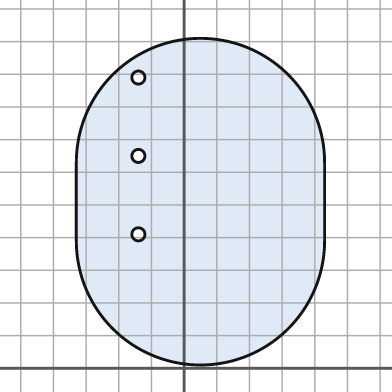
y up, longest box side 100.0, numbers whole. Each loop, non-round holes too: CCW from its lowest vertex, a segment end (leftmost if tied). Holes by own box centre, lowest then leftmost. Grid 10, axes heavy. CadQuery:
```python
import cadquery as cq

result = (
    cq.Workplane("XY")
    .moveTo(-33.0, 39.0)
    .threePointArc((5.0, 1.0), (43.0, 39.0))
    .lineTo(43.0, 63.0)
    .threePointArc((5.0, 101.0), (-33.0, 63.0))
    .close()
    .moveTo(-14.0, 41.0)
    .circle(2.0)
    .moveTo(-14.0, 65.0)
    .circle(2.0)
    .moveTo(-14.0, 89.0)
    .circle(2.0)
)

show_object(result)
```